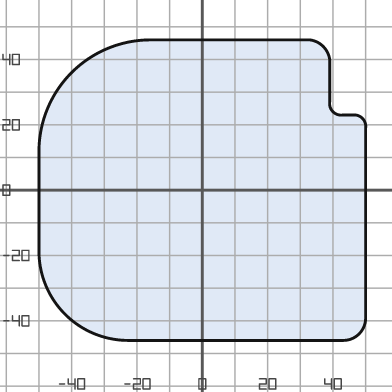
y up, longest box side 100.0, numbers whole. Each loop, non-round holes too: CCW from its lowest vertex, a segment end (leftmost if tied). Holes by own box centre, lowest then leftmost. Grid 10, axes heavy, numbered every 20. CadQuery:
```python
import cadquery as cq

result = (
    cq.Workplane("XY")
    .moveTo(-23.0, -46.0)
    .lineTo(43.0, -46.0)
    .threePointArc((48.0, -44.0), (50.0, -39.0))
    .lineTo(50.0, 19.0)
    .threePointArc((49.0, 22.0), (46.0, 23.0))
    .lineTo(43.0, 23.0)
    .threePointArc((40.0, 24.0), (39.0, 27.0))
    .lineTo(39.0, 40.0)
    .threePointArc((37.0, 44.0), (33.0, 46.0))
    .lineTo(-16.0, 46.0)
    .threePointArc((-40.0, 36.0), (-50.0, 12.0))
    .lineTo(-50.0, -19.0)
    .threePointArc((-42.0, -38.0), (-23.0, -46.0))
    .close()
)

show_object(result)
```